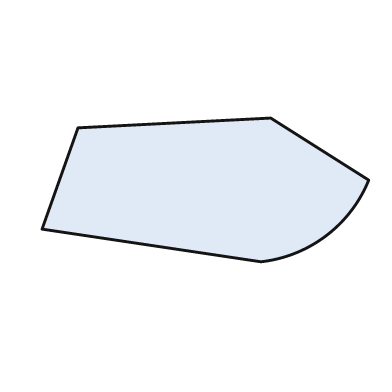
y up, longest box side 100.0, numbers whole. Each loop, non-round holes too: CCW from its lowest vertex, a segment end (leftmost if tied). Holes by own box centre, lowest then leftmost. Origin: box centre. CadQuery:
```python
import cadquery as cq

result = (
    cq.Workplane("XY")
    .moveTo(17.0, -22.0)
    .threePointArc((37.0, -14.0), (50.0, 3.0))
    .lineTo(20.0, 22.0)
    .lineTo(-39.0, 19.0)
    .lineTo(-50.0, -12.0)
    .close()
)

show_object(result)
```